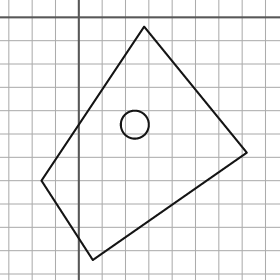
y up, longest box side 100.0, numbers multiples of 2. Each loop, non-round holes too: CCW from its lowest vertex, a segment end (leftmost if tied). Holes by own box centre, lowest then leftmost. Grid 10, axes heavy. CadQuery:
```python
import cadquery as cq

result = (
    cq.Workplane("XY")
    .moveTo(6.0, -104.0)
    .lineTo(72.0, -58.0)
    .lineTo(28.0, -4.0)
    .lineTo(-16.0, -70.0)
    .close()
    .moveTo(24.0, -46.0)
    .circle(6.0)
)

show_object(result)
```